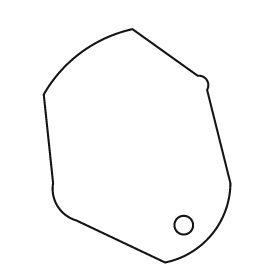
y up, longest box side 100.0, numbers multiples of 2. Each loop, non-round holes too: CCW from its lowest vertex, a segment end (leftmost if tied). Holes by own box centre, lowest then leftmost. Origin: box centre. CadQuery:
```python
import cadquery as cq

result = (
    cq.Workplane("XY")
    .moveTo(12.0, -50.0)
    .threePointArc((32.0, -38.0), (40.0, -16.0))
    .lineTo(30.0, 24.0)
    .threePointArc((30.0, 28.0), (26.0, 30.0))
    .lineTo(-2.0, 50.0)
    .threePointArc((-24.0, 40.0), (-40.0, 22.0))
    .lineTo(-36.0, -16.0)
    .threePointArc((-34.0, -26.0), (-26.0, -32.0))
    .close()
    .moveTo(20.0, -34.0)
    .circle(4.0)
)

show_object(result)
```